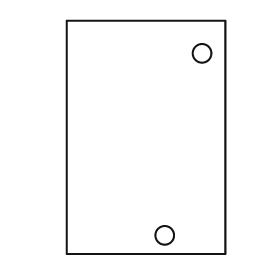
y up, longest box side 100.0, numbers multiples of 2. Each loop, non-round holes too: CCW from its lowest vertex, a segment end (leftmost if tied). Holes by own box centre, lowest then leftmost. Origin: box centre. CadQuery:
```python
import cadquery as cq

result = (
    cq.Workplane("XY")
    .moveTo(-34.0, -50.0)
    .lineTo(34.0, -50.0)
    .lineTo(34.0, 50.0)
    .lineTo(-34.0, 50.0)
    .close()
    .moveTo(8.0, -42.0)
    .circle(4.0)
    .moveTo(24.0, 36.0)
    .circle(4.0)
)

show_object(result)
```